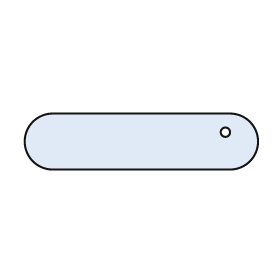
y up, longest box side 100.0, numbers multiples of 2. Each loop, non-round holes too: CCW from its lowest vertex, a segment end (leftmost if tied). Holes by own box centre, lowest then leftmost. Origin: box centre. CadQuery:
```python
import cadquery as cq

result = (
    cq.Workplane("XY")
    .moveTo(-38.0, -12.0)
    .lineTo(38.0, -12.0)
    .threePointArc((50.0, 0.0), (38.0, 12.0))
    .lineTo(-38.0, 12.0)
    .threePointArc((-50.0, 0.0), (-38.0, -12.0))
    .close()
    .moveTo(36.0, 4.0)
    .circle(2.0)
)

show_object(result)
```